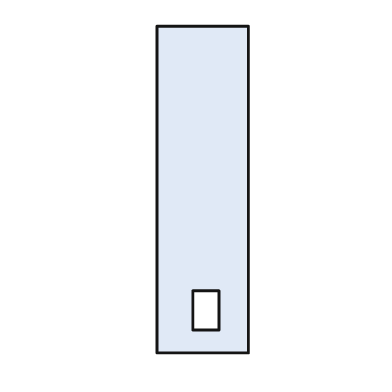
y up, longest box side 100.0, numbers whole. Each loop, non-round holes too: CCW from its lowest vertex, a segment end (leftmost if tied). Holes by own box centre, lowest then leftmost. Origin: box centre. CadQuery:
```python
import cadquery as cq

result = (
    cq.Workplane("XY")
    .moveTo(-14.0, -50.0)
    .lineTo(14.0, -50.0)
    .lineTo(14.0, 50.0)
    .lineTo(-14.0, 50.0)
    .close()
    .moveTo(-3.0, -43.0)
    .lineTo(5.0, -43.0)
    .lineTo(5.0, -31.0)
    .lineTo(-3.0, -31.0)
    .close()
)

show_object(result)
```